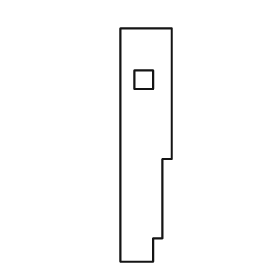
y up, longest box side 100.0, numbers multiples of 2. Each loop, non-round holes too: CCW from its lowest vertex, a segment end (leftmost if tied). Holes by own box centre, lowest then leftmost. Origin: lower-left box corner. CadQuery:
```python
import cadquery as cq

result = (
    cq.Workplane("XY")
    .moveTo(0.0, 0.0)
    .lineTo(14.0, 0.0)
    .lineTo(14.0, 10.0)
    .lineTo(18.0, 10.0)
    .lineTo(18.0, 44.0)
    .lineTo(22.0, 44.0)
    .lineTo(22.0, 100.0)
    .lineTo(0.0, 100.0)
    .close()
    .moveTo(6.0, 74.0)
    .lineTo(14.0, 74.0)
    .lineTo(14.0, 82.0)
    .lineTo(6.0, 82.0)
    .close()
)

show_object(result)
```